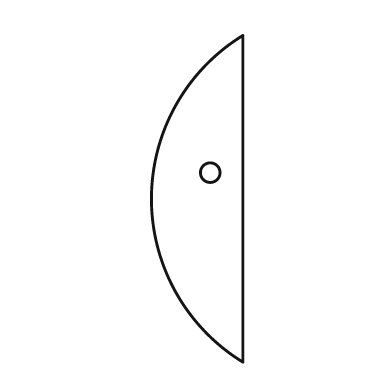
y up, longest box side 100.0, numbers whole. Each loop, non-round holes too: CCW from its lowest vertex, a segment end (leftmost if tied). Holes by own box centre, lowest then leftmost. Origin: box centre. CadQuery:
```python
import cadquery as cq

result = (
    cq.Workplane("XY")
    .moveTo(14.0, -50.0)
    .lineTo(14.0, 50.0)
    .threePointArc((-14.0, 0.0), (14.0, -50.0))
    .close()
    .moveTo(4.0, 8.0)
    .circle(3.0)
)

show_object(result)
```